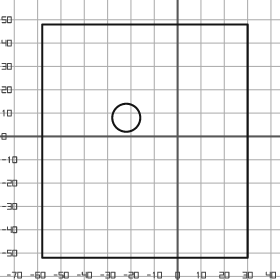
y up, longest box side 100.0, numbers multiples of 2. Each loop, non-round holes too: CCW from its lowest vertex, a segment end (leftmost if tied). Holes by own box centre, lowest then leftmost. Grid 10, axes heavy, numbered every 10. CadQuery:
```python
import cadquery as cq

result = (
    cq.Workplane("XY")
    .moveTo(-58.0, -52.0)
    .lineTo(30.0, -52.0)
    .lineTo(30.0, 48.0)
    .lineTo(-58.0, 48.0)
    .close()
    .moveTo(-22.0, 8.0)
    .circle(6.0)
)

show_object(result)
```